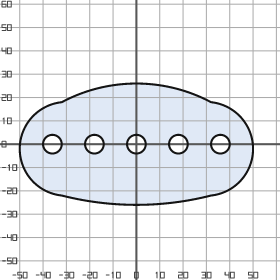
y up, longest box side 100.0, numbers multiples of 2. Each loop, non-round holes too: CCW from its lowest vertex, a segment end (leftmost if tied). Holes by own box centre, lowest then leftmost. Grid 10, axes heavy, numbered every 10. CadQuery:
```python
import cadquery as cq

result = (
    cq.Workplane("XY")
    .moveTo(-32.0, -22.0)
    .threePointArc((0.0, -26.0), (32.0, -22.0))
    .threePointArc((50.0, -2.0), (32.0, 18.0))
    .threePointArc((0.0, 26.0), (-32.0, 18.0))
    .threePointArc((-50.0, -2.0), (-32.0, -22.0))
    .close()
    .moveTo(-36.0, 0.0)
    .circle(4.0)
    .moveTo(-18.0, 0.0)
    .circle(4.0)
    .moveTo(0.0, 0.0)
    .circle(4.0)
    .moveTo(18.0, 0.0)
    .circle(4.0)
    .moveTo(36.0, 0.0)
    .circle(4.0)
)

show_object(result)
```